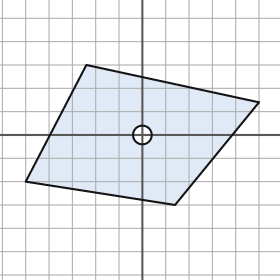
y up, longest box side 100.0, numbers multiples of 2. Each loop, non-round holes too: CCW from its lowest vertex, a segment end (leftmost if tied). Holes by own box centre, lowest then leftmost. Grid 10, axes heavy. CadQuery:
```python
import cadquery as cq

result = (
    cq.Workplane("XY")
    .moveTo(14.0, -30.0)
    .lineTo(50.0, 14.0)
    .lineTo(-24.0, 30.0)
    .lineTo(-50.0, -20.0)
    .close()
    .moveTo(0.0, 0.0)
    .circle(4.0)
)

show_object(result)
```